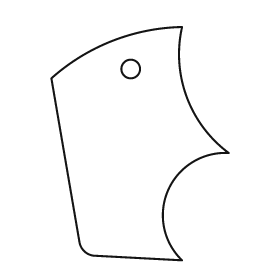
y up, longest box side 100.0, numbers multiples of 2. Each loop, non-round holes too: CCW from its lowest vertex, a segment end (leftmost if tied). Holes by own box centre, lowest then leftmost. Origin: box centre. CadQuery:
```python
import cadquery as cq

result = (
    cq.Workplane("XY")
    .moveTo(18.0, -50.0)
    .threePointArc((12.0, -20.0), (38.0, -4.0))
    .threePointArc((20.0, 20.0), (18.0, 50.0))
    .threePointArc((-12.0, 44.0), (-38.0, 28.0))
    .lineTo(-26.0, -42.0)
    .threePointArc((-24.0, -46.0), (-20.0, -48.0))
    .close()
    .moveTo(-4.0, 32.0)
    .circle(4.0)
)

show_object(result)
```